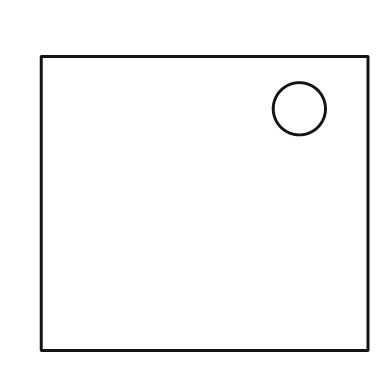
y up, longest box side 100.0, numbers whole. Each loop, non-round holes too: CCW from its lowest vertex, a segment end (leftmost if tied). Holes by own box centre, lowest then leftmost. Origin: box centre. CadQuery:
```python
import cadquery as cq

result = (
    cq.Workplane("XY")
    .moveTo(-50.0, -45.0)
    .lineTo(50.0, -45.0)
    .lineTo(50.0, 45.0)
    .lineTo(-50.0, 45.0)
    .close()
    .moveTo(29.0, 29.0)
    .circle(8.0)
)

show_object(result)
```